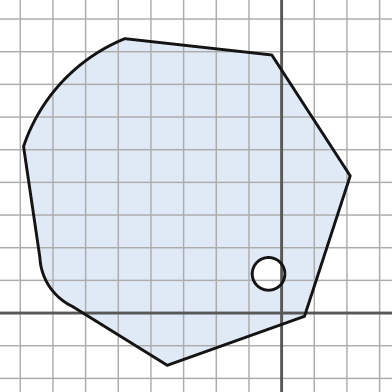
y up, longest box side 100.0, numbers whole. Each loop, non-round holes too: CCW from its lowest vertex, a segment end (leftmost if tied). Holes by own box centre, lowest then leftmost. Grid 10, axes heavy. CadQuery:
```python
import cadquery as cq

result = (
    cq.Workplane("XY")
    .moveTo(-35.0, -16.0)
    .lineTo(7.0, -1.0)
    .lineTo(21.0, 42.0)
    .lineTo(-3.0, 79.0)
    .lineTo(-48.0, 84.0)
    .threePointArc((-67.0, 71.0), (-79.0, 51.0))
    .lineTo(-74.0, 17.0)
    .threePointArc((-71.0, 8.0), (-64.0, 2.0))
    .close()
    .moveTo(-4.0, 12.0)
    .circle(5.0)
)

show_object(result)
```